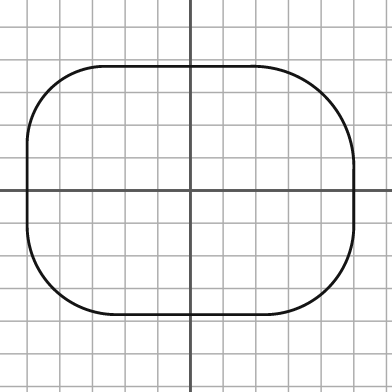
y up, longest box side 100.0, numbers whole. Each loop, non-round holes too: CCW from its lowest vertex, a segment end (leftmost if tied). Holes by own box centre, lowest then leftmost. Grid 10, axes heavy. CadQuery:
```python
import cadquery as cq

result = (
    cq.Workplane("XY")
    .moveTo(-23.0, -38.0)
    .lineTo(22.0, -38.0)
    .threePointArc((42.0, -30.0), (50.0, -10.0))
    .lineTo(50.0, 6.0)
    .threePointArc((41.0, 29.0), (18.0, 38.0))
    .lineTo(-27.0, 38.0)
    .threePointArc((-43.0, 31.0), (-50.0, 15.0))
    .lineTo(-50.0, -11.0)
    .threePointArc((-42.0, -30.0), (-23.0, -38.0))
    .close()
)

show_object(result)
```